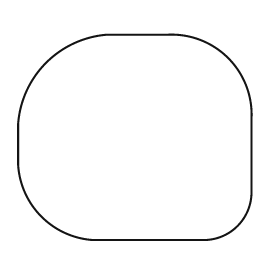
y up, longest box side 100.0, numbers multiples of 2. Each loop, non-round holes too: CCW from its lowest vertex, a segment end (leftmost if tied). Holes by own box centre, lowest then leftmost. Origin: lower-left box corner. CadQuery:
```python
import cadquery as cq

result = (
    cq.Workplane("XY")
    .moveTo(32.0, 0.0)
    .lineTo(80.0, 0.0)
    .threePointArc((94.0, 6.0), (100.0, 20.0))
    .lineTo(100.0, 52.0)
    .threePointArc((90.0, 78.0), (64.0, 88.0))
    .lineTo(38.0, 88.0)
    .threePointArc((12.0, 76.0), (0.0, 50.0))
    .lineTo(0.0, 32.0)
    .threePointArc((10.0, 10.0), (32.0, 0.0))
    .close()
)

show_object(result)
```